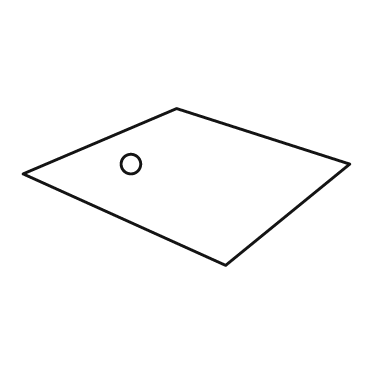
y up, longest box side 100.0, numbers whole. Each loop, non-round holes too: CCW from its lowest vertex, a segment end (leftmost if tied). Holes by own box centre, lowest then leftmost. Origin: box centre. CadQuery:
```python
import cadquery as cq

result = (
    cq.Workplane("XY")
    .moveTo(12.0, -24.0)
    .lineTo(50.0, 7.0)
    .lineTo(-3.0, 24.0)
    .lineTo(-50.0, 4.0)
    .close()
    .moveTo(-17.0, 7.0)
    .circle(3.0)
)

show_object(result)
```